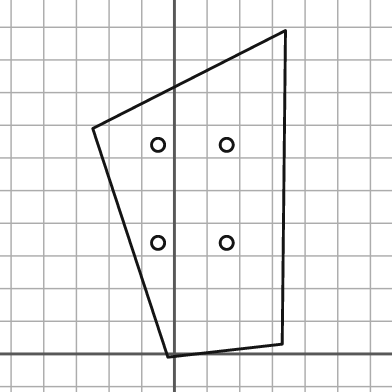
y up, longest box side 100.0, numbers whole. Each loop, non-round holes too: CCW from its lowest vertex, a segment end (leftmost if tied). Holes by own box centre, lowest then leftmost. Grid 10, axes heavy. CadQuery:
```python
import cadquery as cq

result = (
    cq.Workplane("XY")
    .moveTo(-2.0, -1.0)
    .lineTo(33.0, 3.0)
    .lineTo(34.0, 99.0)
    .lineTo(-25.0, 69.0)
    .close()
    .moveTo(-5.0, 34.0)
    .circle(2.0)
    .moveTo(16.0, 34.0)
    .circle(2.0)
    .moveTo(-5.0, 64.0)
    .circle(2.0)
    .moveTo(16.0, 64.0)
    .circle(2.0)
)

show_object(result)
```